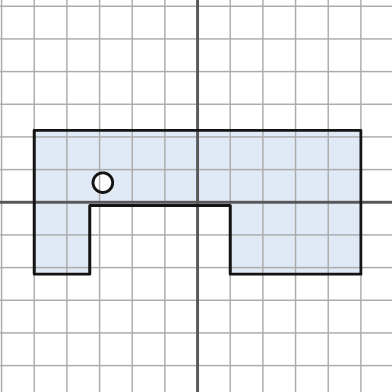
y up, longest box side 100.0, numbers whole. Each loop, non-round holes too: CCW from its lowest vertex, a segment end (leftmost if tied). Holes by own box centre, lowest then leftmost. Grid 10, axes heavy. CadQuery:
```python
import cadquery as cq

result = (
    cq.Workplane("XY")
    .moveTo(-50.0, -22.0)
    .lineTo(-33.0, -22.0)
    .lineTo(-33.0, -1.0)
    .lineTo(10.0, -1.0)
    .lineTo(10.0, -22.0)
    .lineTo(50.0, -22.0)
    .lineTo(50.0, 22.0)
    .lineTo(-50.0, 22.0)
    .close()
    .moveTo(-29.0, 6.0)
    .circle(3.0)
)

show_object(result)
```